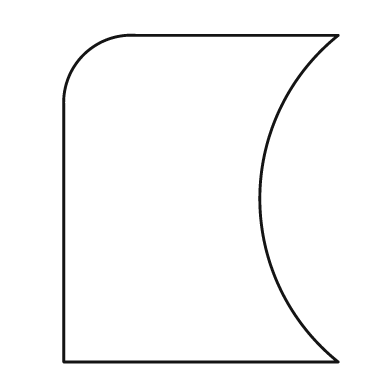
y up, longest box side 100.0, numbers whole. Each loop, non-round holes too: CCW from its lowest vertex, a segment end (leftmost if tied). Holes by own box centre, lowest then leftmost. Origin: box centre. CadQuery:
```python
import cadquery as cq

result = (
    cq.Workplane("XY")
    .moveTo(-42.0, -50.0)
    .lineTo(42.0, -50.0)
    .threePointArc((18.0, 0.0), (42.0, 50.0))
    .lineTo(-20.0, 50.0)
    .threePointArc((-36.0, 44.0), (-42.0, 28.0))
    .close()
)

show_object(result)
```